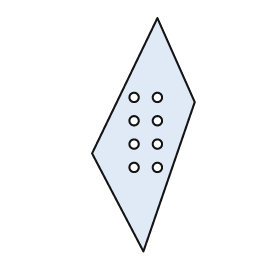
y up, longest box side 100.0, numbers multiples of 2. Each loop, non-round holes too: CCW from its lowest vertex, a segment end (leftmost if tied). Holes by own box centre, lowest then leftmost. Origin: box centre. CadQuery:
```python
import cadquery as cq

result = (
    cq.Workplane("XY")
    .moveTo(0.0, -50.0)
    .lineTo(22.0, 14.0)
    .lineTo(6.0, 50.0)
    .lineTo(-22.0, -8.0)
    .close()
    .moveTo(-4.0, -14.0)
    .circle(2.0)
    .moveTo(6.0, -14.0)
    .circle(2.0)
    .moveTo(-4.0, -4.0)
    .circle(2.0)
    .moveTo(6.0, -4.0)
    .circle(2.0)
    .moveTo(-4.0, 6.0)
    .circle(2.0)
    .moveTo(6.0, 6.0)
    .circle(2.0)
    .moveTo(-4.0, 16.0)
    .circle(2.0)
    .moveTo(6.0, 16.0)
    .circle(2.0)
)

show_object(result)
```